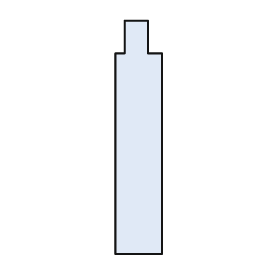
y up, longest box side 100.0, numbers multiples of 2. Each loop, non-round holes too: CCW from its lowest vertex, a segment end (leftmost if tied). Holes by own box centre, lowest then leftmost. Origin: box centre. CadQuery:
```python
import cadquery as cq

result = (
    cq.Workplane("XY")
    .moveTo(-10.0, -50.0)
    .lineTo(10.0, -50.0)
    .lineTo(10.0, 36.0)
    .lineTo(4.0, 36.0)
    .lineTo(4.0, 50.0)
    .lineTo(-6.0, 50.0)
    .lineTo(-6.0, 36.0)
    .lineTo(-10.0, 36.0)
    .close()
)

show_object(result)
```